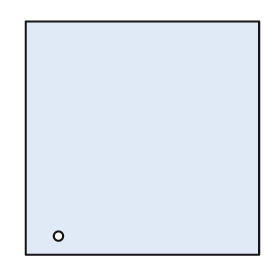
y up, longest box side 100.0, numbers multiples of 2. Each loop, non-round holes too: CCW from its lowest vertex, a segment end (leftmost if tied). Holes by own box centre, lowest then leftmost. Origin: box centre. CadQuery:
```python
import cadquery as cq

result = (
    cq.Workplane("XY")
    .moveTo(-50.0, -50.0)
    .lineTo(50.0, -50.0)
    .lineTo(50.0, 50.0)
    .lineTo(-50.0, 50.0)
    .close()
    .moveTo(-36.0, -42.0)
    .circle(2.0)
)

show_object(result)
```